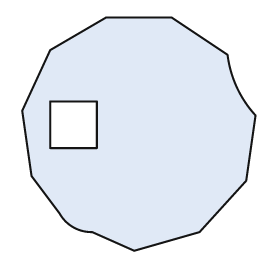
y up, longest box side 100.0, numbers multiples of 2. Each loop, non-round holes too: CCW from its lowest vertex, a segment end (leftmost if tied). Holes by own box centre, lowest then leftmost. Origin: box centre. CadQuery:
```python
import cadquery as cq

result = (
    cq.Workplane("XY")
    .moveTo(-2.0, -50.0)
    .lineTo(26.0, -42.0)
    .lineTo(46.0, -20.0)
    .lineTo(50.0, 8.0)
    .threePointArc((42.0, 20.0), (38.0, 34.0))
    .lineTo(14.0, 50.0)
    .lineTo(-14.0, 50.0)
    .lineTo(-38.0, 36.0)
    .lineTo(-50.0, 10.0)
    .lineTo(-46.0, -18.0)
    .lineTo(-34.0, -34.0)
    .threePointArc((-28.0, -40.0), (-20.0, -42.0))
    .close()
    .moveTo(-38.0, -6.0)
    .lineTo(-18.0, -6.0)
    .lineTo(-18.0, 14.0)
    .lineTo(-38.0, 14.0)
    .close()
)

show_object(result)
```